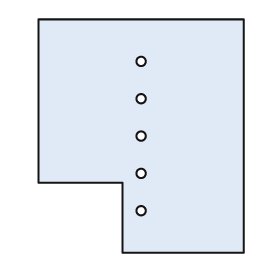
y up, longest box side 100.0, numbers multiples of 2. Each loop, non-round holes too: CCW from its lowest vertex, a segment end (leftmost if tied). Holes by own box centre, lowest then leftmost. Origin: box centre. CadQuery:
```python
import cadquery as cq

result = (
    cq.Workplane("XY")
    .moveTo(-8.0, -50.0)
    .lineTo(44.0, -50.0)
    .lineTo(44.0, 50.0)
    .lineTo(-44.0, 50.0)
    .lineTo(-44.0, -20.0)
    .lineTo(-8.0, -20.0)
    .close()
    .moveTo(0.0, -32.0)
    .circle(2.0)
    .moveTo(0.0, -16.0)
    .circle(2.0)
    .moveTo(0.0, 0.0)
    .circle(2.0)
    .moveTo(0.0, 16.0)
    .circle(2.0)
    .moveTo(0.0, 32.0)
    .circle(2.0)
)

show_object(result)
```